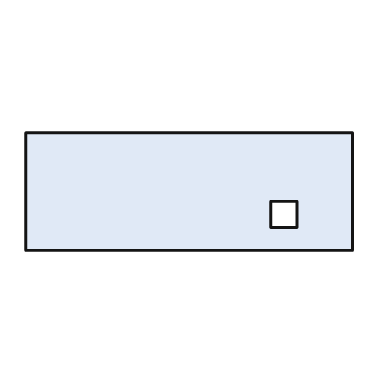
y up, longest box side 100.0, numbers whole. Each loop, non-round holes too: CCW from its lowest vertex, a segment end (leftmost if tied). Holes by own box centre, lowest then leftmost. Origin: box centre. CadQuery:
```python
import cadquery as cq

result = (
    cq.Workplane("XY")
    .moveTo(-50.0, -18.0)
    .lineTo(50.0, -18.0)
    .lineTo(50.0, 18.0)
    .lineTo(-50.0, 18.0)
    .close()
    .moveTo(25.0, -11.0)
    .lineTo(33.0, -11.0)
    .lineTo(33.0, -3.0)
    .lineTo(25.0, -3.0)
    .close()
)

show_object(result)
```